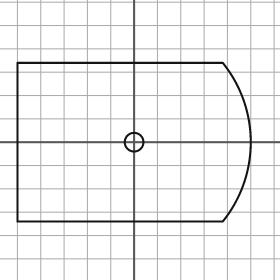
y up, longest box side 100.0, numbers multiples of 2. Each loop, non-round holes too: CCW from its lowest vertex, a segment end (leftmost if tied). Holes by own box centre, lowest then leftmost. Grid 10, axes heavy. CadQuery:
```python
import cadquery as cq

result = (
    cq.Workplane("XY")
    .moveTo(-50.0, -34.0)
    .lineTo(38.0, -34.0)
    .threePointArc((50.0, 0.0), (38.0, 34.0))
    .lineTo(-50.0, 34.0)
    .close()
    .moveTo(0.0, 0.0)
    .circle(4.0)
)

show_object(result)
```